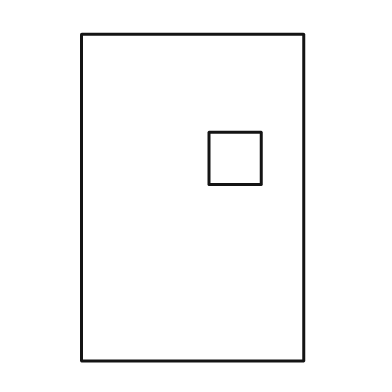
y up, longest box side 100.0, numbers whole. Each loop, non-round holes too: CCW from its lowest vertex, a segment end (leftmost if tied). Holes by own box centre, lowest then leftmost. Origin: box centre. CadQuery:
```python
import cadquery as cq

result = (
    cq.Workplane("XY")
    .moveTo(-34.0, -50.0)
    .lineTo(34.0, -50.0)
    .lineTo(34.0, 50.0)
    .lineTo(-34.0, 50.0)
    .close()
    .moveTo(5.0, 4.0)
    .lineTo(21.0, 4.0)
    .lineTo(21.0, 20.0)
    .lineTo(5.0, 20.0)
    .close()
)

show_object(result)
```